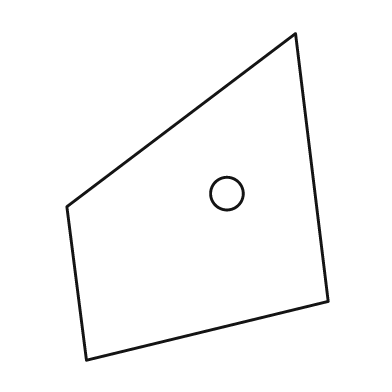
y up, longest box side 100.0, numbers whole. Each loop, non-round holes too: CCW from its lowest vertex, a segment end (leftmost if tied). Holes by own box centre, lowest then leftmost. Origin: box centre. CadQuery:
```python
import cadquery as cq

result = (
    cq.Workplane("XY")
    .moveTo(-34.0, -50.0)
    .lineTo(40.0, -32.0)
    .lineTo(30.0, 50.0)
    .lineTo(-40.0, -3.0)
    .close()
    .moveTo(9.0, 1.0)
    .circle(5.0)
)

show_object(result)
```